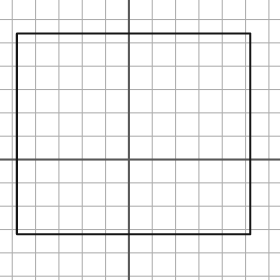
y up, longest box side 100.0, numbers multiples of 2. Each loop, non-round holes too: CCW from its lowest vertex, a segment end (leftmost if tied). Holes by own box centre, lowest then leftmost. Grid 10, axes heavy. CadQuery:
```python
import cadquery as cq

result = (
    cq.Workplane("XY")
    .moveTo(-48.0, -32.0)
    .lineTo(52.0, -32.0)
    .lineTo(52.0, 54.0)
    .lineTo(-48.0, 54.0)
    .close()
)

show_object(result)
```